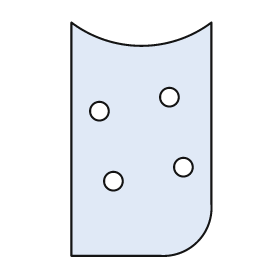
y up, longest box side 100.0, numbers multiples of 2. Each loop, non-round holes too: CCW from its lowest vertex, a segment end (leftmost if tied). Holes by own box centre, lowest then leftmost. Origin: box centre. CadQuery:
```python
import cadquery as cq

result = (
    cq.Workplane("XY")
    .moveTo(-30.0, -50.0)
    .lineTo(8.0, -50.0)
    .threePointArc((24.0, -44.0), (30.0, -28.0))
    .lineTo(30.0, 50.0)
    .threePointArc((0.0, 40.0), (-30.0, 50.0))
    .close()
    .moveTo(-12.0, -18.0)
    .circle(4.0)
    .moveTo(18.0, -12.0)
    .circle(4.0)
    .moveTo(-18.0, 12.0)
    .circle(4.0)
    .moveTo(12.0, 18.0)
    .circle(4.0)
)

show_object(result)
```